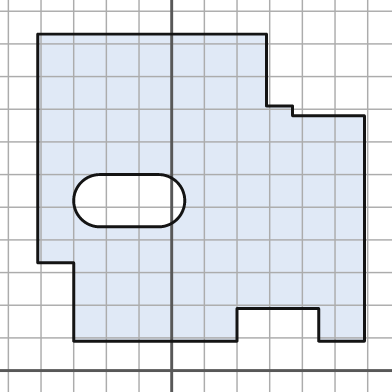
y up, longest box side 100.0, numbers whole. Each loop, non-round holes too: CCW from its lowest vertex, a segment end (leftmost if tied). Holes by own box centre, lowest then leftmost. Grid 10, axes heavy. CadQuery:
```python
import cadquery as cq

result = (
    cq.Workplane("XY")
    .moveTo(-30.0, 9.0)
    .lineTo(20.0, 9.0)
    .lineTo(20.0, 19.0)
    .lineTo(45.0, 19.0)
    .lineTo(45.0, 9.0)
    .lineTo(59.0, 9.0)
    .lineTo(59.0, 78.0)
    .lineTo(37.0, 78.0)
    .lineTo(37.0, 81.0)
    .lineTo(29.0, 81.0)
    .lineTo(29.0, 103.0)
    .lineTo(-41.0, 103.0)
    .lineTo(-41.0, 33.0)
    .lineTo(-30.0, 33.0)
    .close()
    .moveTo(-22.0, 44.0)
    .lineTo(-4.0, 44.0)
    .threePointArc((4.0, 52.0), (-4.0, 60.0))
    .lineTo(-22.0, 60.0)
    .threePointArc((-30.0, 52.0), (-22.0, 44.0))
    .close()
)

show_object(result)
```